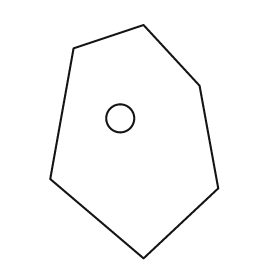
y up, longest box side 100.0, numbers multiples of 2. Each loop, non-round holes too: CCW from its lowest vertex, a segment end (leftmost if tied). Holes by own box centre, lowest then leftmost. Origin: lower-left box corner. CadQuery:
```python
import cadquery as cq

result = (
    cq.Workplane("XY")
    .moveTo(40.0, 0.0)
    .lineTo(72.0, 30.0)
    .lineTo(64.0, 74.0)
    .lineTo(40.0, 100.0)
    .lineTo(10.0, 90.0)
    .lineTo(0.0, 34.0)
    .close()
    .moveTo(30.0, 60.0)
    .circle(6.0)
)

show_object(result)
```